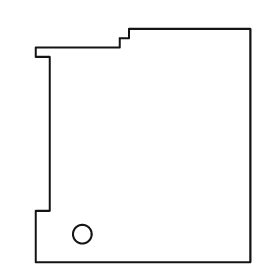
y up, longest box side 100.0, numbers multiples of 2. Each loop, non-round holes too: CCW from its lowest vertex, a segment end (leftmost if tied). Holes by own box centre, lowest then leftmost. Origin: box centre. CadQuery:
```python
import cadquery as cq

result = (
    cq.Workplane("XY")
    .moveTo(-46.0, -50.0)
    .lineTo(46.0, -50.0)
    .lineTo(46.0, 50.0)
    .lineTo(-6.0, 50.0)
    .lineTo(-6.0, 46.0)
    .lineTo(-10.0, 46.0)
    .lineTo(-10.0, 42.0)
    .lineTo(-46.0, 42.0)
    .lineTo(-46.0, 38.0)
    .lineTo(-40.0, 38.0)
    .lineTo(-40.0, -28.0)
    .lineTo(-46.0, -28.0)
    .close()
    .moveTo(-26.0, -38.0)
    .circle(4.0)
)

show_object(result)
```